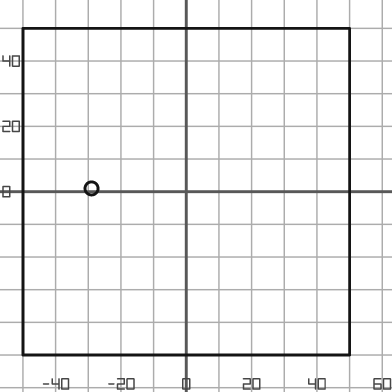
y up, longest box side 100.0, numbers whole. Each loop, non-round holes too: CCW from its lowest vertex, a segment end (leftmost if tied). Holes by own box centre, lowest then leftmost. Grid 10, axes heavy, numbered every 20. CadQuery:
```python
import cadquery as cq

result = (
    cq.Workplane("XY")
    .moveTo(-50.0, -50.0)
    .lineTo(50.0, -50.0)
    .lineTo(50.0, 50.0)
    .lineTo(-50.0, 50.0)
    .close()
    .moveTo(-29.0, 1.0)
    .circle(2.0)
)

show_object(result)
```